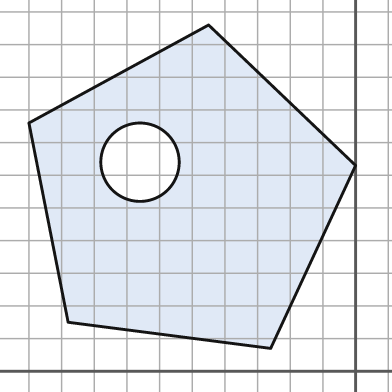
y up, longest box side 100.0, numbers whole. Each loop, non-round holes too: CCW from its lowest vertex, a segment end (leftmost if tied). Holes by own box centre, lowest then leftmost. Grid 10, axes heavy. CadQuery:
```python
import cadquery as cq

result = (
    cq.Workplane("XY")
    .moveTo(-26.0, 7.0)
    .lineTo(0.0, 63.0)
    .lineTo(-45.0, 106.0)
    .lineTo(-100.0, 76.0)
    .lineTo(-88.0, 15.0)
    .close()
    .moveTo(-66.0, 64.0)
    .circle(12.0)
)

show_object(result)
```